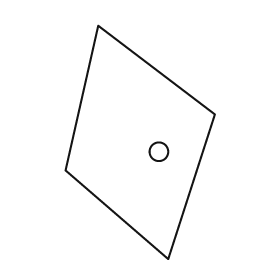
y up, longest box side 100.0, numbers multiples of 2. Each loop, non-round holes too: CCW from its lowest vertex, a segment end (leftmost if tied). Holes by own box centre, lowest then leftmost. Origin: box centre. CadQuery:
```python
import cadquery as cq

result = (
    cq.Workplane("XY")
    .moveTo(12.0, -50.0)
    .lineTo(32.0, 12.0)
    .lineTo(-18.0, 50.0)
    .lineTo(-32.0, -12.0)
    .close()
    .moveTo(8.0, -4.0)
    .circle(4.0)
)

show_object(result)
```